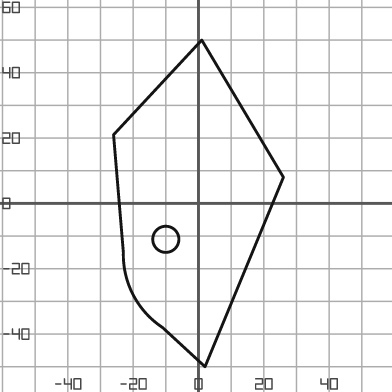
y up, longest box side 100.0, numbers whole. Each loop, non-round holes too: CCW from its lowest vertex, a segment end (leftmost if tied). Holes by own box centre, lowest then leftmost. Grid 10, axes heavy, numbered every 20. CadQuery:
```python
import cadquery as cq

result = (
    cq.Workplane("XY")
    .moveTo(2.0, -50.0)
    .lineTo(26.0, 8.0)
    .lineTo(1.0, 50.0)
    .lineTo(-26.0, 21.0)
    .lineTo(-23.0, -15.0)
    .threePointArc((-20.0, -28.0), (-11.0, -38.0))
    .close()
    .moveTo(-10.0, -11.0)
    .circle(4.0)
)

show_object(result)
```